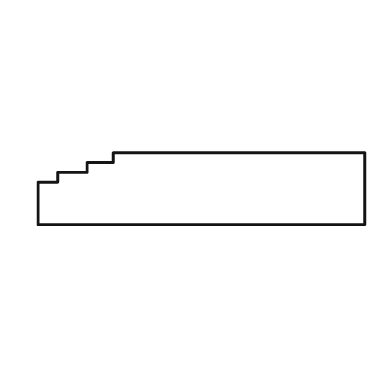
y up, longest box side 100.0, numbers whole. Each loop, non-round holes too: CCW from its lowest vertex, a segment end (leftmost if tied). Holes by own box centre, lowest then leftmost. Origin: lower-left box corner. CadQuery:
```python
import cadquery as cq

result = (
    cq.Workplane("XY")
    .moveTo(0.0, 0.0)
    .lineTo(100.0, 0.0)
    .lineTo(100.0, 22.0)
    .lineTo(23.0, 22.0)
    .lineTo(23.0, 19.0)
    .lineTo(15.0, 19.0)
    .lineTo(15.0, 16.0)
    .lineTo(6.0, 16.0)
    .lineTo(6.0, 13.0)
    .lineTo(0.0, 13.0)
    .close()
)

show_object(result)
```